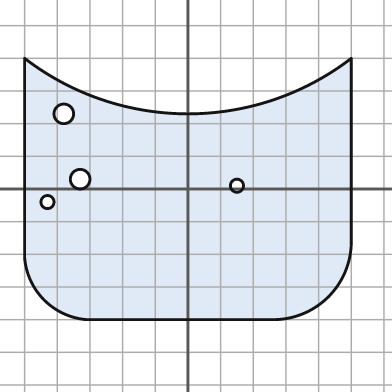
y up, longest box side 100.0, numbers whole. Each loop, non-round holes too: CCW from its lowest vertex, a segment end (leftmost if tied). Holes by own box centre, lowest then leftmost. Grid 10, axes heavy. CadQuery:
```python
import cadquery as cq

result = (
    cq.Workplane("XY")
    .moveTo(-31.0, -40.0)
    .lineTo(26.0, -40.0)
    .threePointArc((43.0, -33.0), (50.0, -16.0))
    .lineTo(50.0, 40.0)
    .threePointArc((0.0, 23.0), (-50.0, 40.0))
    .lineTo(-50.0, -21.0)
    .threePointArc((-44.0, -34.0), (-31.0, -40.0))
    .close()
    .moveTo(-43.0, -4.0)
    .circle(2.0)
    .moveTo(15.0, 1.0)
    .circle(2.0)
    .moveTo(-33.0, 3.0)
    .circle(3.0)
    .moveTo(-38.0, 23.0)
    .circle(3.0)
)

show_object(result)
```